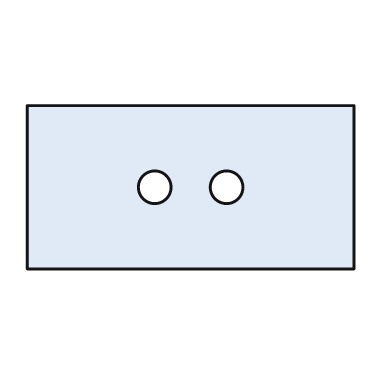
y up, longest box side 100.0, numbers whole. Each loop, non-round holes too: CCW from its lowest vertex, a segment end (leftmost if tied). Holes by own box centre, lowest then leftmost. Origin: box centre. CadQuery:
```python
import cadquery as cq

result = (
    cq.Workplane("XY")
    .moveTo(-50.0, -25.0)
    .lineTo(50.0, -25.0)
    .lineTo(50.0, 25.0)
    .lineTo(-50.0, 25.0)
    .close()
    .moveTo(-11.0, 0.0)
    .circle(5.0)
    .moveTo(11.0, 0.0)
    .circle(5.0)
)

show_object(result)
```